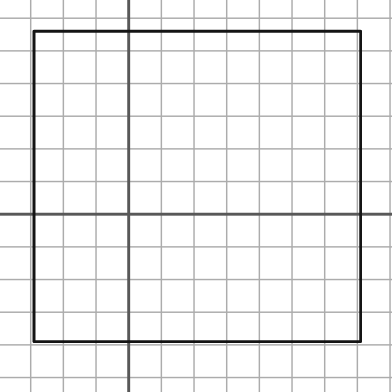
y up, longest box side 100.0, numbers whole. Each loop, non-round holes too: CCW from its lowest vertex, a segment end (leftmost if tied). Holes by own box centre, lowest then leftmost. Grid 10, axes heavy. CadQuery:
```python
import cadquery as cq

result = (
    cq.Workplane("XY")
    .moveTo(-29.0, -39.0)
    .lineTo(71.0, -39.0)
    .lineTo(71.0, 56.0)
    .lineTo(-29.0, 56.0)
    .close()
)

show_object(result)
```